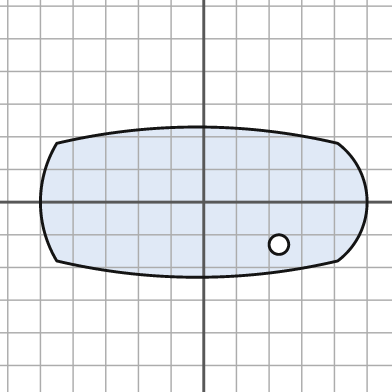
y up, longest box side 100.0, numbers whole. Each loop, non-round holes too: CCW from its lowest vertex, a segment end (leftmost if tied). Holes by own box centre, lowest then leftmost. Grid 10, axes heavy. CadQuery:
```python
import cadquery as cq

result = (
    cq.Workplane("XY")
    .moveTo(-45.0, -18.0)
    .threePointArc((-2.0, -23.0), (41.0, -18.0))
    .threePointArc((50.0, 0.0), (41.0, 18.0))
    .threePointArc((-2.0, 23.0), (-45.0, 18.0))
    .threePointArc((-50.0, 0.0), (-45.0, -18.0))
    .close()
    .moveTo(23.0, -13.0)
    .circle(3.0)
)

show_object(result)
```